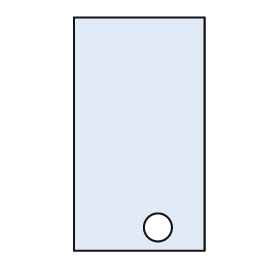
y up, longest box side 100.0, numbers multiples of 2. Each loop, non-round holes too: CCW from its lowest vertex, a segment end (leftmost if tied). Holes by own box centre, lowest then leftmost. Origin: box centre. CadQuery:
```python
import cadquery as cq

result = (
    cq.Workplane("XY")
    .moveTo(-28.0, -50.0)
    .lineTo(28.0, -50.0)
    .lineTo(28.0, 50.0)
    .lineTo(-28.0, 50.0)
    .close()
    .moveTo(8.0, -40.0)
    .circle(6.0)
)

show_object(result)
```